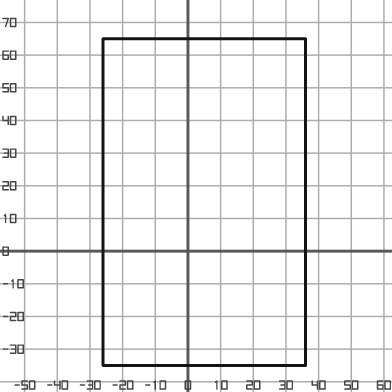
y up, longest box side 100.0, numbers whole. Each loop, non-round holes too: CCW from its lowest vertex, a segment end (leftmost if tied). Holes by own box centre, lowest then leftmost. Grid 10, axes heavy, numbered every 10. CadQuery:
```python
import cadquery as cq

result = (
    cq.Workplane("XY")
    .moveTo(-26.0, -35.0)
    .lineTo(36.0, -35.0)
    .lineTo(36.0, 65.0)
    .lineTo(-26.0, 65.0)
    .close()
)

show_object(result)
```